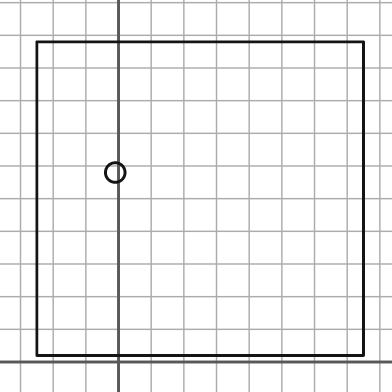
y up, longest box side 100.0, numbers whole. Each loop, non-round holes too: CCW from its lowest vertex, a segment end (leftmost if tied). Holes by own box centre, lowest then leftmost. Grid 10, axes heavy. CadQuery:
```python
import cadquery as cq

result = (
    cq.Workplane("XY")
    .moveTo(-25.0, 2.0)
    .lineTo(75.0, 2.0)
    .lineTo(75.0, 98.0)
    .lineTo(-25.0, 98.0)
    .close()
    .moveTo(-1.0, 58.0)
    .circle(3.0)
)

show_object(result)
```